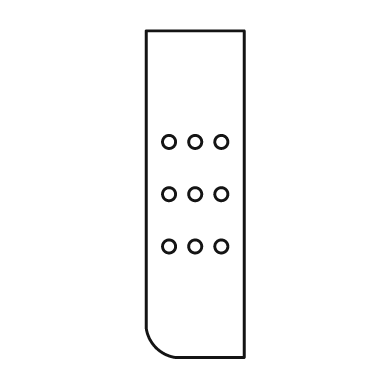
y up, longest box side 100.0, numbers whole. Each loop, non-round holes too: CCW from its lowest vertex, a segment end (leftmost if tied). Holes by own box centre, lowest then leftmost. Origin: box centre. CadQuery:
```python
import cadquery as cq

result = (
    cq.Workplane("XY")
    .moveTo(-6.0, -50.0)
    .lineTo(15.0, -50.0)
    .lineTo(15.0, 50.0)
    .lineTo(-15.0, 50.0)
    .lineTo(-15.0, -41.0)
    .threePointArc((-12.0, -47.0), (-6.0, -50.0))
    .close()
    .moveTo(-8.0, -16.0)
    .circle(2.0)
    .moveTo(0.0, -16.0)
    .circle(2.0)
    .moveTo(8.0, -16.0)
    .circle(2.0)
    .moveTo(-8.0, 0.0)
    .circle(2.0)
    .moveTo(0.0, 0.0)
    .circle(2.0)
    .moveTo(8.0, 0.0)
    .circle(2.0)
    .moveTo(-8.0, 16.0)
    .circle(2.0)
    .moveTo(0.0, 16.0)
    .circle(2.0)
    .moveTo(8.0, 16.0)
    .circle(2.0)
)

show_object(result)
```